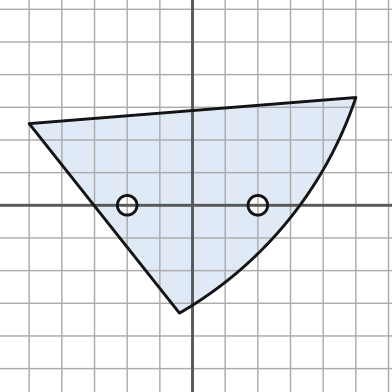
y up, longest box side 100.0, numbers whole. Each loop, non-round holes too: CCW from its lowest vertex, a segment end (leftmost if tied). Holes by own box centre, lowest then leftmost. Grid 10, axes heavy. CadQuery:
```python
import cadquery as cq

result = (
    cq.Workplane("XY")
    .moveTo(-4.0, -33.0)
    .threePointArc((29.0, -5.0), (50.0, 33.0))
    .lineTo(-50.0, 25.0)
    .close()
    .moveTo(-20.0, 0.0)
    .circle(3.0)
    .moveTo(20.0, 0.0)
    .circle(3.0)
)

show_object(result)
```